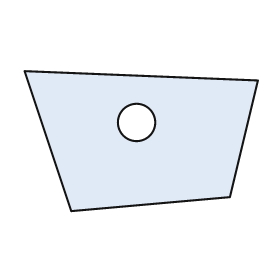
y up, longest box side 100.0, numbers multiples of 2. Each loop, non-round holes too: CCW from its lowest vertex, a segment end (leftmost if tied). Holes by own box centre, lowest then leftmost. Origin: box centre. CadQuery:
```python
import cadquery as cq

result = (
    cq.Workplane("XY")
    .moveTo(-30.0, -30.0)
    .lineTo(38.0, -24.0)
    .lineTo(50.0, 26.0)
    .lineTo(-50.0, 30.0)
    .close()
    .moveTo(-2.0, 8.0)
    .circle(8.0)
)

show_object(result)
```